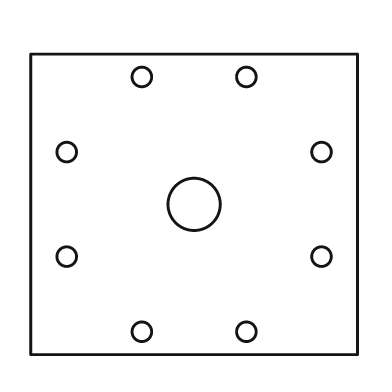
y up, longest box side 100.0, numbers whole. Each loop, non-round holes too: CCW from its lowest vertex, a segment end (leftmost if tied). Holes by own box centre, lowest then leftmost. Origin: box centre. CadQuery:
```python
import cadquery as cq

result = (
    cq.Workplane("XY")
    .moveTo(-50.0, -46.0)
    .lineTo(50.0, -46.0)
    .lineTo(50.0, 46.0)
    .lineTo(-50.0, 46.0)
    .close()
    .moveTo(-16.0, -39.0)
    .circle(3.0)
    .moveTo(16.0, -39.0)
    .circle(3.0)
    .moveTo(-39.0, -16.0)
    .circle(3.0)
    .moveTo(39.0, -16.0)
    .circle(3.0)
    .moveTo(0.0, 0.0)
    .circle(8.0)
    .moveTo(-39.0, 16.0)
    .circle(3.0)
    .moveTo(39.0, 16.0)
    .circle(3.0)
    .moveTo(-16.0, 39.0)
    .circle(3.0)
    .moveTo(16.0, 39.0)
    .circle(3.0)
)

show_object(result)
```